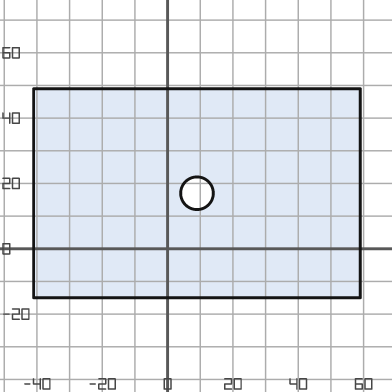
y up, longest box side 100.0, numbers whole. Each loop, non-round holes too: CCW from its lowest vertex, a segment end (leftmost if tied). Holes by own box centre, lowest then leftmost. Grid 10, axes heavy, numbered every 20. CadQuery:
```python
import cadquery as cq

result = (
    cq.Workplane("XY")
    .moveTo(-41.0, -15.0)
    .lineTo(59.0, -15.0)
    .lineTo(59.0, 49.0)
    .lineTo(-41.0, 49.0)
    .close()
    .moveTo(9.0, 17.0)
    .circle(5.0)
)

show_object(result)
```